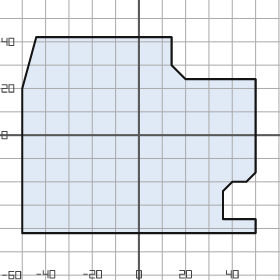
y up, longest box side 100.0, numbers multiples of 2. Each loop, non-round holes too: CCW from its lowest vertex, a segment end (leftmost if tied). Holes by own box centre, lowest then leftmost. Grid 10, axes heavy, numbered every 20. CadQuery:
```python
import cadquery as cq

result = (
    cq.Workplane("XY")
    .moveTo(-50.0, -42.0)
    .lineTo(50.0, -42.0)
    .lineTo(50.0, -36.0)
    .lineTo(36.0, -36.0)
    .lineTo(36.0, -24.0)
    .lineTo(40.0, -20.0)
    .lineTo(46.0, -20.0)
    .lineTo(50.0, -16.0)
    .lineTo(50.0, 24.0)
    .lineTo(20.0, 24.0)
    .lineTo(14.0, 30.0)
    .lineTo(14.0, 42.0)
    .lineTo(-44.0, 42.0)
    .lineTo(-50.0, 20.0)
    .close()
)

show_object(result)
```